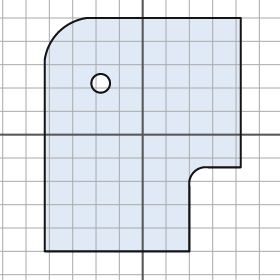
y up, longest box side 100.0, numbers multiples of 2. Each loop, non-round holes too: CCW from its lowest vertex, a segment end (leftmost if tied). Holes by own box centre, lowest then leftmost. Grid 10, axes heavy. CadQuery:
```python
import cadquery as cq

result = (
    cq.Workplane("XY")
    .moveTo(-42.0, -50.0)
    .lineTo(20.0, -50.0)
    .lineTo(20.0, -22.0)
    .threePointArc((22.0, -16.0), (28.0, -14.0))
    .lineTo(42.0, -14.0)
    .lineTo(42.0, 50.0)
    .lineTo(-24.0, 50.0)
    .threePointArc((-36.0, 44.0), (-42.0, 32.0))
    .close()
    .moveTo(-18.0, 22.0)
    .circle(4.0)
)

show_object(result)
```